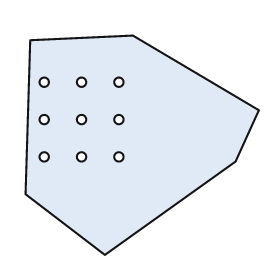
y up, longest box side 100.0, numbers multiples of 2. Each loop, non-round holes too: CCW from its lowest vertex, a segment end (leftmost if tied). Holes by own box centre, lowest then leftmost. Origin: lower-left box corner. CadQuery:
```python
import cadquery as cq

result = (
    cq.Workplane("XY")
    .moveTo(34.0, 0.0)
    .lineTo(90.0, 40.0)
    .lineTo(100.0, 62.0)
    .lineTo(46.0, 94.0)
    .lineTo(2.0, 92.0)
    .lineTo(0.0, 26.0)
    .close()
    .moveTo(8.0, 42.0)
    .circle(2.0)
    .moveTo(24.0, 42.0)
    .circle(2.0)
    .moveTo(40.0, 42.0)
    .circle(2.0)
    .moveTo(8.0, 58.0)
    .circle(2.0)
    .moveTo(24.0, 58.0)
    .circle(2.0)
    .moveTo(40.0, 58.0)
    .circle(2.0)
    .moveTo(8.0, 74.0)
    .circle(2.0)
    .moveTo(24.0, 74.0)
    .circle(2.0)
    .moveTo(40.0, 74.0)
    .circle(2.0)
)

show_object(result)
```